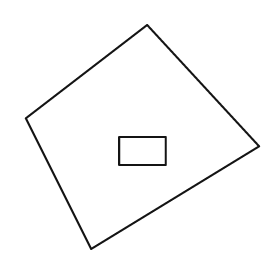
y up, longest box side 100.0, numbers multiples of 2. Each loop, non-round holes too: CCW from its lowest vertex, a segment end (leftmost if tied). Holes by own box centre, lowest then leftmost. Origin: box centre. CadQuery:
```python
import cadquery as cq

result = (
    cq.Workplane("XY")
    .moveTo(-22.0, -48.0)
    .lineTo(50.0, -4.0)
    .lineTo(2.0, 48.0)
    .lineTo(-50.0, 8.0)
    .close()
    .moveTo(-10.0, -12.0)
    .lineTo(10.0, -12.0)
    .lineTo(10.0, 0.0)
    .lineTo(-10.0, 0.0)
    .close()
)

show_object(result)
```